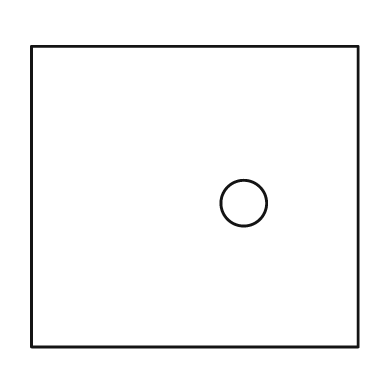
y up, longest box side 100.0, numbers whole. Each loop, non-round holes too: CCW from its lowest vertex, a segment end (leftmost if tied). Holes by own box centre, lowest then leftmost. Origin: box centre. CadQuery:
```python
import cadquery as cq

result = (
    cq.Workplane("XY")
    .moveTo(-50.0, -46.0)
    .lineTo(50.0, -46.0)
    .lineTo(50.0, 46.0)
    .lineTo(-50.0, 46.0)
    .close()
    .moveTo(15.0, -2.0)
    .circle(7.0)
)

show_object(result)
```